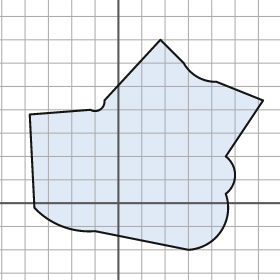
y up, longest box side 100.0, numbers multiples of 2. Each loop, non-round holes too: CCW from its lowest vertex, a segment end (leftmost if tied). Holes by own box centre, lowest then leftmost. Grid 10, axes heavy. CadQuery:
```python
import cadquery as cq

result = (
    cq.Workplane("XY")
    .moveTo(30.0, -20.0)
    .threePointArc((44.0, -12.0), (46.0, 4.0))
    .threePointArc((50.0, 12.0), (46.0, 20.0))
    .lineTo(62.0, 44.0)
    .lineTo(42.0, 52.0)
    .threePointArc((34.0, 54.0), (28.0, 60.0))
    .lineTo(18.0, 70.0)
    .lineTo(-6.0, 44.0)
    .threePointArc((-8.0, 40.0), (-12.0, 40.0))
    .lineTo(-38.0, 38.0)
    .lineTo(-36.0, -2.0)
    .threePointArc((-24.0, -10.0), (-10.0, -12.0))
    .close()
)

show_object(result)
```